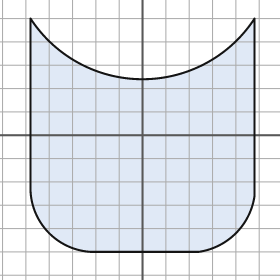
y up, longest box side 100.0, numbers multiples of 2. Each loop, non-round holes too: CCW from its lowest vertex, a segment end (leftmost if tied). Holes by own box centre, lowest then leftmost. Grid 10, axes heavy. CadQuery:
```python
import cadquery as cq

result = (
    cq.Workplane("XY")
    .moveTo(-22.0, -50.0)
    .lineTo(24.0, -50.0)
    .threePointArc((40.0, -42.0), (48.0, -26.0))
    .lineTo(48.0, 50.0)
    .threePointArc((0.0, 24.0), (-48.0, 50.0))
    .lineTo(-48.0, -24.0)
    .threePointArc((-40.0, -42.0), (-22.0, -50.0))
    .close()
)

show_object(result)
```